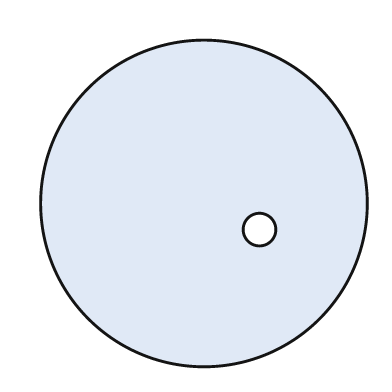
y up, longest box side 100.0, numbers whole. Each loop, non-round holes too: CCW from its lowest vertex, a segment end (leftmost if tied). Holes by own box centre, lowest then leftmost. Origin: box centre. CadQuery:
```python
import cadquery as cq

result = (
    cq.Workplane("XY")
    .moveTo(0.0, 0.0)
    .circle(50.0)
    .moveTo(17.0, -8.0)
    .circle(5.0)
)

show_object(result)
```